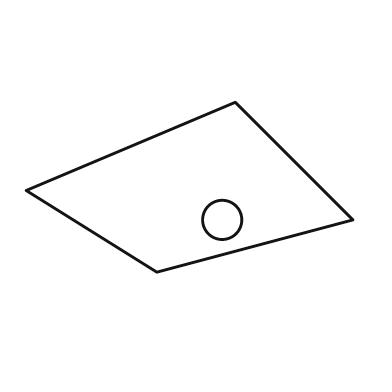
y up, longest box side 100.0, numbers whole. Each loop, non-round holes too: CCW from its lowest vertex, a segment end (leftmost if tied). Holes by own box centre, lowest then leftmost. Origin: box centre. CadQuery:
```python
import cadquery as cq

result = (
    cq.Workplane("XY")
    .moveTo(-10.0, -26.0)
    .lineTo(50.0, -10.0)
    .lineTo(14.0, 26.0)
    .lineTo(-50.0, -1.0)
    .close()
    .moveTo(10.0, -10.0)
    .circle(6.0)
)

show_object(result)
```